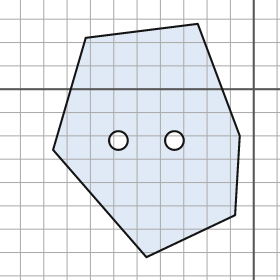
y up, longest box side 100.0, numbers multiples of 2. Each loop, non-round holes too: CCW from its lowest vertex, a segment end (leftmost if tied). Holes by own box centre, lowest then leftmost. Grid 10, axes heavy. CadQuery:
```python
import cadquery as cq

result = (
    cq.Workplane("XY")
    .moveTo(-46.0, -72.0)
    .lineTo(-8.0, -54.0)
    .lineTo(-6.0, -20.0)
    .lineTo(-24.0, 28.0)
    .lineTo(-72.0, 22.0)
    .lineTo(-86.0, -26.0)
    .close()
    .moveTo(-58.0, -22.0)
    .circle(4.0)
    .moveTo(-34.0, -22.0)
    .circle(4.0)
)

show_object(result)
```